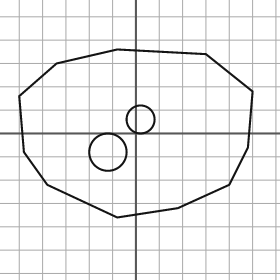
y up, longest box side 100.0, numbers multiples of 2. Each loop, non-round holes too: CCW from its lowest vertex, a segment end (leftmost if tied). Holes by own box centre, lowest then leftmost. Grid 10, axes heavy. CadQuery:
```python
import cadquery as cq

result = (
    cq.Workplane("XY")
    .moveTo(-8.0, -36.0)
    .lineTo(18.0, -32.0)
    .lineTo(40.0, -22.0)
    .lineTo(48.0, -6.0)
    .lineTo(50.0, 18.0)
    .lineTo(30.0, 34.0)
    .lineTo(-8.0, 36.0)
    .lineTo(-34.0, 30.0)
    .lineTo(-50.0, 16.0)
    .lineTo(-48.0, -8.0)
    .lineTo(-38.0, -22.0)
    .close()
    .moveTo(-12.0, -8.0)
    .circle(8.0)
    .moveTo(2.0, 6.0)
    .circle(6.0)
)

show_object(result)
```